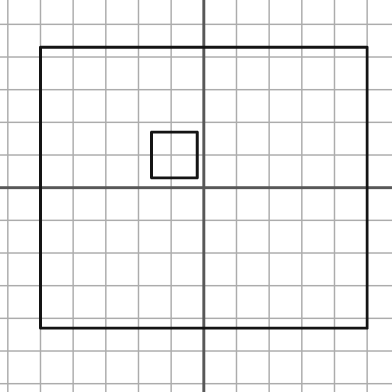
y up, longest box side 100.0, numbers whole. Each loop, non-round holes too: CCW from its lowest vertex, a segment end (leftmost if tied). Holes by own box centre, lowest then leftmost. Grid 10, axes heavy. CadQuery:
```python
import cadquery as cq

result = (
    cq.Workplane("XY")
    .moveTo(-50.0, -43.0)
    .lineTo(50.0, -43.0)
    .lineTo(50.0, 43.0)
    .lineTo(-50.0, 43.0)
    .close()
    .moveTo(-16.0, 3.0)
    .lineTo(-2.0, 3.0)
    .lineTo(-2.0, 17.0)
    .lineTo(-16.0, 17.0)
    .close()
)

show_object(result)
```